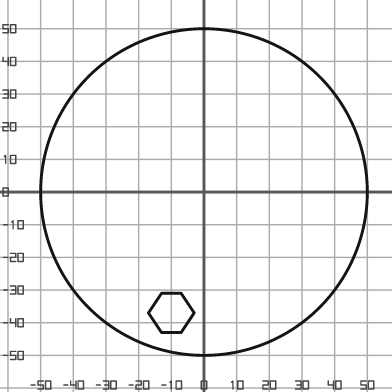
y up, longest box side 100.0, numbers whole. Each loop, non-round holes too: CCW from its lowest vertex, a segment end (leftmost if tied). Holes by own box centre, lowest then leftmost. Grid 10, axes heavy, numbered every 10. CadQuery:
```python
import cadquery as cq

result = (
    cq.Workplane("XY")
    .moveTo(0.0, 0.0)
    .circle(50.0)
    .moveTo(-13.0, -43.0)
    .lineTo(-7.0, -43.0)
    .lineTo(-3.0, -37.0)
    .lineTo(-7.0, -31.0)
    .lineTo(-13.0, -31.0)
    .lineTo(-17.0, -37.0)
    .close()
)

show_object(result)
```